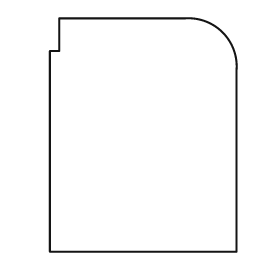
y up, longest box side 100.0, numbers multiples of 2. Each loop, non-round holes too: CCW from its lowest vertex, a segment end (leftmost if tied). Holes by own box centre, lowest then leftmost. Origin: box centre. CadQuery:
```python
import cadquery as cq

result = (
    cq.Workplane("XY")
    .moveTo(-40.0, -50.0)
    .lineTo(40.0, -50.0)
    .lineTo(40.0, 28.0)
    .threePointArc((34.0, 44.0), (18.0, 50.0))
    .lineTo(-36.0, 50.0)
    .lineTo(-36.0, 36.0)
    .lineTo(-40.0, 36.0)
    .close()
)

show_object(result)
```